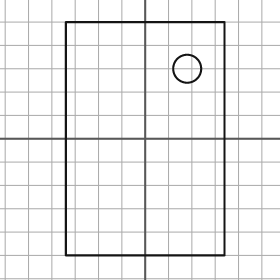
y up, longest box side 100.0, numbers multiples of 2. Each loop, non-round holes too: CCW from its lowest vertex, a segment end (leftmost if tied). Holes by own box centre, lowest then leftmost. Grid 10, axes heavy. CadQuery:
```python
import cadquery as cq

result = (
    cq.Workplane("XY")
    .moveTo(-34.0, -50.0)
    .lineTo(34.0, -50.0)
    .lineTo(34.0, 50.0)
    .lineTo(-34.0, 50.0)
    .close()
    .moveTo(18.0, 30.0)
    .circle(6.0)
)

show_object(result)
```